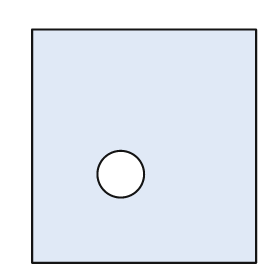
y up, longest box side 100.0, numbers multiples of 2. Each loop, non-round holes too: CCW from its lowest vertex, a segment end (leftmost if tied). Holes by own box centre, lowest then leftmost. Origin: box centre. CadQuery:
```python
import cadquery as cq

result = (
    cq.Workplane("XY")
    .moveTo(-48.0, -50.0)
    .lineTo(48.0, -50.0)
    .lineTo(48.0, 50.0)
    .lineTo(-48.0, 50.0)
    .close()
    .moveTo(-10.0, -12.0)
    .circle(10.0)
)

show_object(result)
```